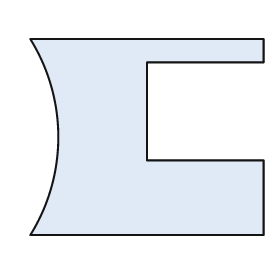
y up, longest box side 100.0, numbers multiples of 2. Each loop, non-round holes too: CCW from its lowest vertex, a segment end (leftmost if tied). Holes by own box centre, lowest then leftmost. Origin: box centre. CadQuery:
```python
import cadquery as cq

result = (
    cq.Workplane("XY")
    .moveTo(-50.0, -42.0)
    .lineTo(50.0, -42.0)
    .lineTo(50.0, -10.0)
    .lineTo(0.0, -10.0)
    .lineTo(0.0, 32.0)
    .lineTo(50.0, 32.0)
    .lineTo(50.0, 42.0)
    .lineTo(-50.0, 42.0)
    .threePointArc((-38.0, 0.0), (-50.0, -42.0))
    .close()
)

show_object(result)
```